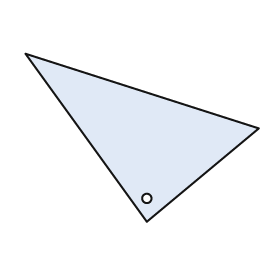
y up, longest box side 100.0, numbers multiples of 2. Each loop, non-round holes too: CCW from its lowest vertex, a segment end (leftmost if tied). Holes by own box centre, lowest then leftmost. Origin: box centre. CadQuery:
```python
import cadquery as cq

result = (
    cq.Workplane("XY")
    .moveTo(2.0, -36.0)
    .lineTo(50.0, 4.0)
    .lineTo(-50.0, 36.0)
    .close()
    .moveTo(2.0, -26.0)
    .circle(2.0)
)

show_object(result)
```